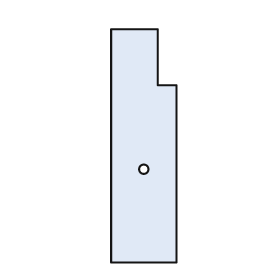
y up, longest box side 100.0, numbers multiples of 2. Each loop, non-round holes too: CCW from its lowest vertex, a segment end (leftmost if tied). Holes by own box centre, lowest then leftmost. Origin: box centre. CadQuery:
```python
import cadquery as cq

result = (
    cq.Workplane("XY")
    .moveTo(-14.0, -50.0)
    .lineTo(14.0, -50.0)
    .lineTo(14.0, 26.0)
    .lineTo(6.0, 26.0)
    .lineTo(6.0, 50.0)
    .lineTo(-14.0, 50.0)
    .close()
    .moveTo(0.0, -10.0)
    .circle(2.0)
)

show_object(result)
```